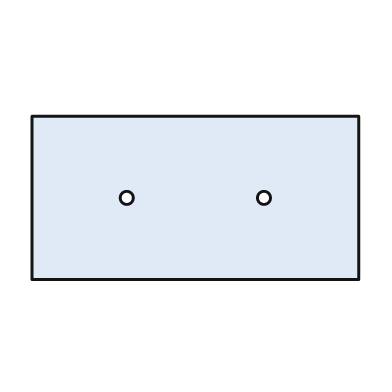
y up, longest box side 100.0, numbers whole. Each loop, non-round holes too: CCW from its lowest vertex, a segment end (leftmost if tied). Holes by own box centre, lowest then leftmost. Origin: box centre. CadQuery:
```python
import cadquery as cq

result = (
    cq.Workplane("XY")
    .moveTo(-50.0, -25.0)
    .lineTo(50.0, -25.0)
    .lineTo(50.0, 25.0)
    .lineTo(-50.0, 25.0)
    .close()
    .moveTo(-21.0, 0.0)
    .circle(2.0)
    .moveTo(21.0, 0.0)
    .circle(2.0)
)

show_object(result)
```